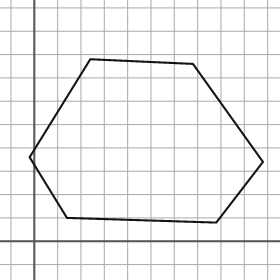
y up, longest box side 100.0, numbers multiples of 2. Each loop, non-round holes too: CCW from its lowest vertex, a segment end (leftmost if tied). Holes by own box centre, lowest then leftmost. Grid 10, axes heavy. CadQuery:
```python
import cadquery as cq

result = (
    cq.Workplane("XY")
    .moveTo(78.0, 8.0)
    .lineTo(98.0, 34.0)
    .lineTo(68.0, 76.0)
    .lineTo(24.0, 78.0)
    .lineTo(-2.0, 36.0)
    .lineTo(14.0, 10.0)
    .close()
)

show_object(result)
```